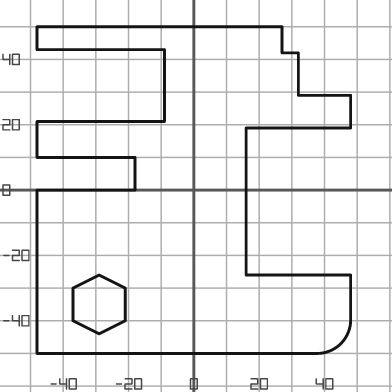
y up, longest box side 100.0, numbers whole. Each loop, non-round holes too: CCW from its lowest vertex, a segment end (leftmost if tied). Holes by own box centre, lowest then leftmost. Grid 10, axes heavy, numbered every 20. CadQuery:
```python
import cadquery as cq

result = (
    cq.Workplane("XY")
    .moveTo(-48.0, -50.0)
    .lineTo(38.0, -50.0)
    .threePointArc((45.0, -47.0), (48.0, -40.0))
    .lineTo(48.0, -26.0)
    .lineTo(16.0, -26.0)
    .lineTo(16.0, 19.0)
    .lineTo(48.0, 19.0)
    .lineTo(48.0, 29.0)
    .lineTo(32.0, 29.0)
    .lineTo(32.0, 42.0)
    .lineTo(27.0, 42.0)
    .lineTo(27.0, 50.0)
    .lineTo(-48.0, 50.0)
    .lineTo(-48.0, 43.0)
    .lineTo(-9.0, 43.0)
    .lineTo(-9.0, 21.0)
    .lineTo(-48.0, 21.0)
    .lineTo(-48.0, 10.0)
    .lineTo(-18.0, 10.0)
    .lineTo(-18.0, 0.0)
    .lineTo(-48.0, 0.0)
    .close()
    .moveTo(-29.0, -44.0)
    .lineTo(-21.0, -40.0)
    .lineTo(-21.0, -30.0)
    .lineTo(-29.0, -26.0)
    .lineTo(-37.0, -30.0)
    .lineTo(-37.0, -40.0)
    .close()
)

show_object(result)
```